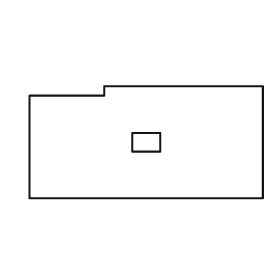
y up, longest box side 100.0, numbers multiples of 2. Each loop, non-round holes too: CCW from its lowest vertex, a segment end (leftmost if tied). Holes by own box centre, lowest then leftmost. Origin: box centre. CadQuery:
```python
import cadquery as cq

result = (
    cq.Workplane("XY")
    .moveTo(-50.0, -24.0)
    .lineTo(50.0, -24.0)
    .lineTo(50.0, 24.0)
    .lineTo(-18.0, 24.0)
    .lineTo(-18.0, 20.0)
    .lineTo(-50.0, 20.0)
    .close()
    .moveTo(-6.0, -4.0)
    .lineTo(6.0, -4.0)
    .lineTo(6.0, 4.0)
    .lineTo(-6.0, 4.0)
    .close()
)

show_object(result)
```